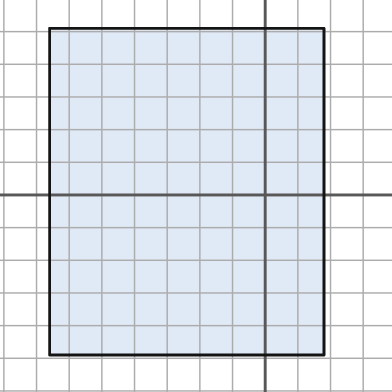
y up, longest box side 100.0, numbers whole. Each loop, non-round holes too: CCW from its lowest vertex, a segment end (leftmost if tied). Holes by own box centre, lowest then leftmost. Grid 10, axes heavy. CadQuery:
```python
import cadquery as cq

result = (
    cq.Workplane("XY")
    .moveTo(-66.0, -49.0)
    .lineTo(18.0, -49.0)
    .lineTo(18.0, 51.0)
    .lineTo(-66.0, 51.0)
    .close()
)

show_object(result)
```